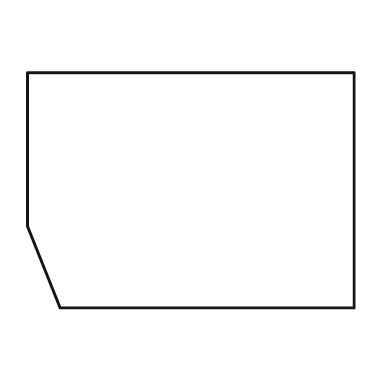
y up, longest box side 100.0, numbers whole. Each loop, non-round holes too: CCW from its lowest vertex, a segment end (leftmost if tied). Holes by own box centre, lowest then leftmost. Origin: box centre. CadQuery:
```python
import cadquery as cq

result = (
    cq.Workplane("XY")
    .moveTo(-40.0, -36.0)
    .lineTo(50.0, -36.0)
    .lineTo(50.0, 36.0)
    .lineTo(-50.0, 36.0)
    .lineTo(-50.0, -11.0)
    .close()
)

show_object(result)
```